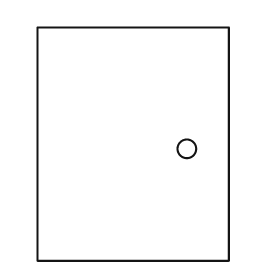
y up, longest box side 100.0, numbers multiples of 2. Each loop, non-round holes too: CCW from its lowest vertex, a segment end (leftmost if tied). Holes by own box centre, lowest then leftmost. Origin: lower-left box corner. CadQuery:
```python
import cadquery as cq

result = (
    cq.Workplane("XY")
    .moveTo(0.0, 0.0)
    .lineTo(82.0, 0.0)
    .lineTo(82.0, 100.0)
    .lineTo(0.0, 100.0)
    .close()
    .moveTo(64.0, 48.0)
    .circle(4.0)
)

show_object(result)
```